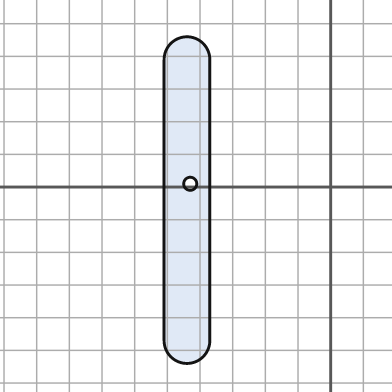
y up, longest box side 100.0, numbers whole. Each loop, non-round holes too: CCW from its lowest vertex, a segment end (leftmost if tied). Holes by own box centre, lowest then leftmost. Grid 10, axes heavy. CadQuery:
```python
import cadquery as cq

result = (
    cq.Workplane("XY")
    .moveTo(-51.0, -47.0)
    .threePointArc((-44.0, -54.0), (-37.0, -47.0))
    .lineTo(-37.0, 39.0)
    .threePointArc((-44.0, 46.0), (-51.0, 39.0))
    .close()
    .moveTo(-43.0, 1.0)
    .circle(2.0)
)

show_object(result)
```